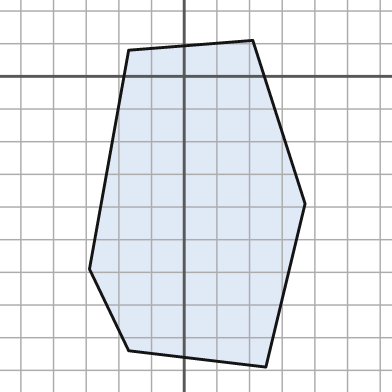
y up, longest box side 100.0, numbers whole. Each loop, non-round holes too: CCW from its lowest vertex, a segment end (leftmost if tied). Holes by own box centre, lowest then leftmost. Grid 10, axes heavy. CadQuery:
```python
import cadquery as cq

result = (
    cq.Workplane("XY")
    .moveTo(25.0, -89.0)
    .lineTo(37.0, -39.0)
    .lineTo(21.0, 11.0)
    .lineTo(-17.0, 8.0)
    .lineTo(-29.0, -59.0)
    .lineTo(-17.0, -84.0)
    .close()
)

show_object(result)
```